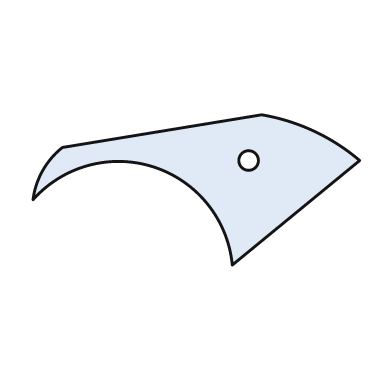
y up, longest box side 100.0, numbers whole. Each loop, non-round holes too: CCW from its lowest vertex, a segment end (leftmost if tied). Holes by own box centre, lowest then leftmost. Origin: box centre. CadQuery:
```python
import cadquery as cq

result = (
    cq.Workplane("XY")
    .moveTo(11.0, -23.0)
    .lineTo(50.0, 9.0)
    .threePointArc((36.0, 18.0), (20.0, 23.0))
    .lineTo(-41.0, 13.0)
    .threePointArc((-47.0, 6.0), (-50.0, -3.0))
    .threePointArc((-13.0, 7.0), (11.0, -23.0))
    .close()
    .moveTo(16.0, 9.0)
    .circle(3.0)
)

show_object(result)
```